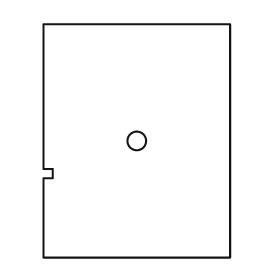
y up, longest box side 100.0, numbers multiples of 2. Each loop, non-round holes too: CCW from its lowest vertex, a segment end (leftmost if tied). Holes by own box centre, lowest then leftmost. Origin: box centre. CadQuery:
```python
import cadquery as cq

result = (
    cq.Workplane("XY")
    .moveTo(-40.0, -50.0)
    .lineTo(40.0, -50.0)
    .lineTo(40.0, 50.0)
    .lineTo(-40.0, 50.0)
    .lineTo(-40.0, -12.0)
    .lineTo(-36.0, -12.0)
    .lineTo(-36.0, -16.0)
    .lineTo(-40.0, -16.0)
    .close()
    .moveTo(0.0, 0.0)
    .circle(4.0)
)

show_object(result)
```